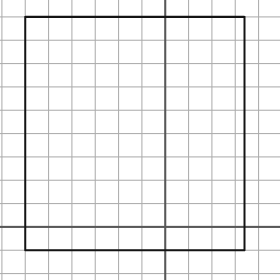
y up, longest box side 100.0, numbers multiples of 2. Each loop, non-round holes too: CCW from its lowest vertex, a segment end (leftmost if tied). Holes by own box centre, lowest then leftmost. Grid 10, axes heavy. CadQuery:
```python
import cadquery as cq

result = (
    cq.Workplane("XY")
    .moveTo(-60.0, -10.0)
    .lineTo(34.0, -10.0)
    .lineTo(34.0, 90.0)
    .lineTo(-60.0, 90.0)
    .close()
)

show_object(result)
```